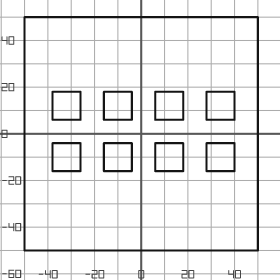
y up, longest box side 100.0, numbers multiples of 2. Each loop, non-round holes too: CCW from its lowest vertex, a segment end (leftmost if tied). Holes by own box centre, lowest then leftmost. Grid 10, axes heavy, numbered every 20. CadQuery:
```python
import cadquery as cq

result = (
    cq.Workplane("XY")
    .moveTo(-50.0, -50.0)
    .lineTo(50.0, -50.0)
    .lineTo(50.0, 50.0)
    .lineTo(-50.0, 50.0)
    .close()
    .moveTo(-38.0, -16.0)
    .lineTo(-26.0, -16.0)
    .lineTo(-26.0, -4.0)
    .lineTo(-38.0, -4.0)
    .close()
    .moveTo(-16.0, -16.0)
    .lineTo(-4.0, -16.0)
    .lineTo(-4.0, -4.0)
    .lineTo(-16.0, -4.0)
    .close()
    .moveTo(6.0, -16.0)
    .lineTo(18.0, -16.0)
    .lineTo(18.0, -4.0)
    .lineTo(6.0, -4.0)
    .close()
    .moveTo(28.0, -16.0)
    .lineTo(40.0, -16.0)
    .lineTo(40.0, -4.0)
    .lineTo(28.0, -4.0)
    .close()
    .moveTo(-38.0, 6.0)
    .lineTo(-26.0, 6.0)
    .lineTo(-26.0, 18.0)
    .lineTo(-38.0, 18.0)
    .close()
    .moveTo(-16.0, 6.0)
    .lineTo(-4.0, 6.0)
    .lineTo(-4.0, 18.0)
    .lineTo(-16.0, 18.0)
    .close()
    .moveTo(6.0, 6.0)
    .lineTo(18.0, 6.0)
    .lineTo(18.0, 18.0)
    .lineTo(6.0, 18.0)
    .close()
    .moveTo(28.0, 6.0)
    .lineTo(40.0, 6.0)
    .lineTo(40.0, 18.0)
    .lineTo(28.0, 18.0)
    .close()
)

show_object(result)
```